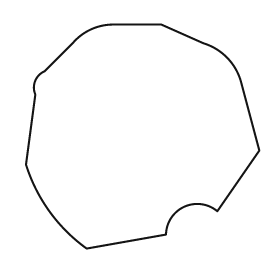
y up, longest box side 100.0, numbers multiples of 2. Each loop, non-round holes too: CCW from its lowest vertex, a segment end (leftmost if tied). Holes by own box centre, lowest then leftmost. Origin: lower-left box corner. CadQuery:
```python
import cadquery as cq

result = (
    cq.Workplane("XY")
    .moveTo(26.0, 0.0)
    .lineTo(60.0, 6.0)
    .threePointArc((68.0, 18.0), (82.0, 16.0))
    .lineTo(100.0, 42.0)
    .lineTo(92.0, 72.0)
    .threePointArc((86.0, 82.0), (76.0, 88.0))
    .lineTo(58.0, 96.0)
    .lineTo(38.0, 96.0)
    .threePointArc((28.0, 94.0), (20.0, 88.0))
    .lineTo(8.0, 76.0)
    .threePointArc((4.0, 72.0), (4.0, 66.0))
    .lineTo(0.0, 36.0)
    .threePointArc((10.0, 16.0), (26.0, 0.0))
    .close()
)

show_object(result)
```